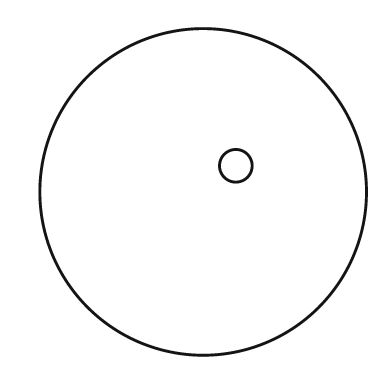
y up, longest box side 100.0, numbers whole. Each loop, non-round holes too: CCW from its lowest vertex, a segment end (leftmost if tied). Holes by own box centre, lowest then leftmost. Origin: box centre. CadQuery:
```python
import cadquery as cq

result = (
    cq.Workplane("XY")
    .moveTo(0.0, 0.0)
    .circle(50.0)
    .moveTo(10.0, 8.0)
    .circle(5.0)
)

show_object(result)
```